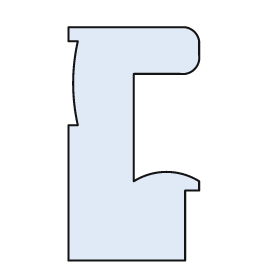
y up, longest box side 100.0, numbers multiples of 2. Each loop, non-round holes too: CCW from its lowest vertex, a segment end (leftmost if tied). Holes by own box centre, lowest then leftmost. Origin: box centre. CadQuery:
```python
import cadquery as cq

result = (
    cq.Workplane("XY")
    .moveTo(-28.0, -50.0)
    .lineTo(22.0, -50.0)
    .lineTo(22.0, -20.0)
    .lineTo(28.0, -20.0)
    .lineTo(28.0, -16.0)
    .threePointArc((14.0, -12.0), (0.0, -16.0))
    .lineTo(0.0, 30.0)
    .lineTo(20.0, 30.0)
    .threePointArc((26.0, 32.0), (28.0, 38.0))
    .lineTo(28.0, 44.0)
    .threePointArc((26.0, 48.0), (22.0, 50.0))
    .lineTo(-28.0, 50.0)
    .lineTo(-28.0, 44.0)
    .lineTo(-24.0, 44.0)
    .threePointArc((-26.0, 26.0), (-24.0, 8.0))
    .lineTo(-28.0, 8.0)
    .close()
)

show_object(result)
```